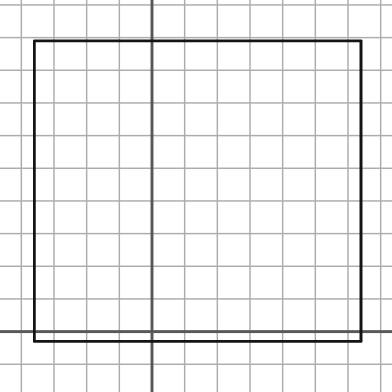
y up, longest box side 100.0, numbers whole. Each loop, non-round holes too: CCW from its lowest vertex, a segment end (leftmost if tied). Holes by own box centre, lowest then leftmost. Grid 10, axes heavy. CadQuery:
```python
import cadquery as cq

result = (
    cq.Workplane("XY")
    .moveTo(-36.0, -3.0)
    .lineTo(64.0, -3.0)
    .lineTo(64.0, 89.0)
    .lineTo(-36.0, 89.0)
    .close()
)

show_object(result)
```